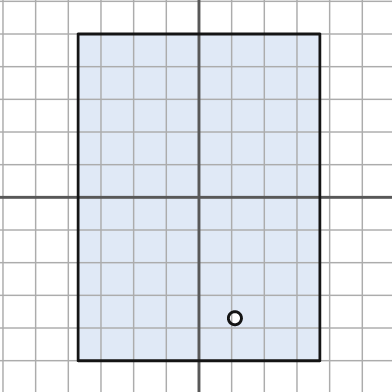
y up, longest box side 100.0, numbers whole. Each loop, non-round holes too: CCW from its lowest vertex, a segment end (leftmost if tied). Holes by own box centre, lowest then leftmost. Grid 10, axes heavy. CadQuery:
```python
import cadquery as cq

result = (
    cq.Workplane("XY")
    .moveTo(-37.0, -50.0)
    .lineTo(37.0, -50.0)
    .lineTo(37.0, 50.0)
    .lineTo(-37.0, 50.0)
    .close()
    .moveTo(11.0, -37.0)
    .circle(2.0)
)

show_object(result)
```